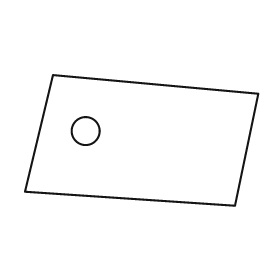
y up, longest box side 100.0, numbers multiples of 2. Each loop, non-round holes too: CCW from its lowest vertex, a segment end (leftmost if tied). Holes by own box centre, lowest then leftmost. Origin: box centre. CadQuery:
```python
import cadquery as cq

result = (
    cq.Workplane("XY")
    .moveTo(40.0, -28.0)
    .lineTo(50.0, 20.0)
    .lineTo(-38.0, 28.0)
    .lineTo(-50.0, -22.0)
    .close()
    .moveTo(-24.0, 4.0)
    .circle(6.0)
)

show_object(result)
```